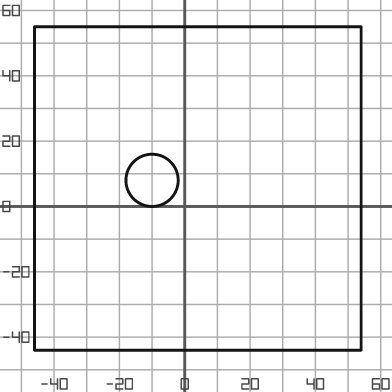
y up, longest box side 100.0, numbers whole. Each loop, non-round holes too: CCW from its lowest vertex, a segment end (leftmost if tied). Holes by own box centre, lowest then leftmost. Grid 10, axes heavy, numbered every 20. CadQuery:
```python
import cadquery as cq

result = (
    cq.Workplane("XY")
    .moveTo(-46.0, -44.0)
    .lineTo(54.0, -44.0)
    .lineTo(54.0, 55.0)
    .lineTo(-46.0, 55.0)
    .close()
    .moveTo(-10.0, 8.0)
    .circle(8.0)
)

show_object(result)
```